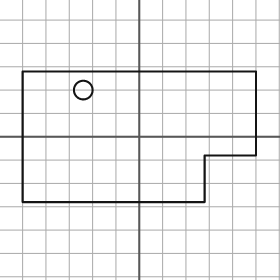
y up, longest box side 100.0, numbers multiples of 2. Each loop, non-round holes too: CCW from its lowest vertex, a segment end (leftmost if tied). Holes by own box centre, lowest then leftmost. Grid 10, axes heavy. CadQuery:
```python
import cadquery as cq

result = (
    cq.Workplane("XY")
    .moveTo(-50.0, -28.0)
    .lineTo(28.0, -28.0)
    .lineTo(28.0, -8.0)
    .lineTo(50.0, -8.0)
    .lineTo(50.0, 28.0)
    .lineTo(-50.0, 28.0)
    .close()
    .moveTo(-24.0, 20.0)
    .circle(4.0)
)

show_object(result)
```